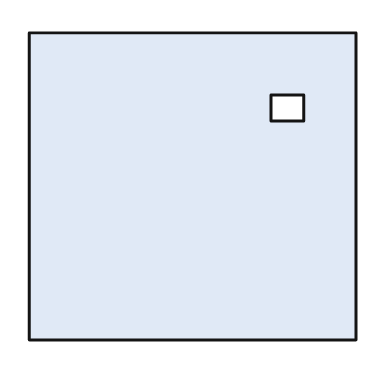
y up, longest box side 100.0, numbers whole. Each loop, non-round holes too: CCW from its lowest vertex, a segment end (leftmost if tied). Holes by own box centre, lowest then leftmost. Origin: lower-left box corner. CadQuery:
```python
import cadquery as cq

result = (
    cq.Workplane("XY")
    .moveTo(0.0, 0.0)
    .lineTo(100.0, 0.0)
    .lineTo(100.0, 94.0)
    .lineTo(0.0, 94.0)
    .close()
    .moveTo(74.0, 67.0)
    .lineTo(84.0, 67.0)
    .lineTo(84.0, 75.0)
    .lineTo(74.0, 75.0)
    .close()
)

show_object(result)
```